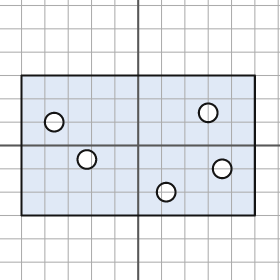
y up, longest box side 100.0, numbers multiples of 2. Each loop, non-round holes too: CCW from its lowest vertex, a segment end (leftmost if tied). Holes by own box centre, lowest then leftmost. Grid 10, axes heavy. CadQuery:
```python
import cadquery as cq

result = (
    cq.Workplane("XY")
    .moveTo(-50.0, -30.0)
    .lineTo(50.0, -30.0)
    .lineTo(50.0, 30.0)
    .lineTo(-50.0, 30.0)
    .close()
    .moveTo(12.0, -20.0)
    .circle(4.0)
    .moveTo(36.0, -10.0)
    .circle(4.0)
    .moveTo(-22.0, -6.0)
    .circle(4.0)
    .moveTo(-36.0, 10.0)
    .circle(4.0)
    .moveTo(30.0, 14.0)
    .circle(4.0)
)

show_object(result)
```